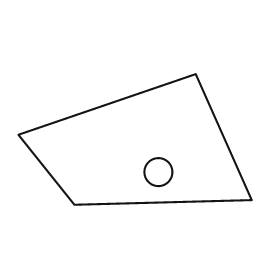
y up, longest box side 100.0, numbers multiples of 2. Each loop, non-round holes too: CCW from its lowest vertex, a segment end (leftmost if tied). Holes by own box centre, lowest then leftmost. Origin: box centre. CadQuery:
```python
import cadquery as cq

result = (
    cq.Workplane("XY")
    .moveTo(-26.0, -28.0)
    .lineTo(50.0, -26.0)
    .lineTo(26.0, 28.0)
    .lineTo(-50.0, 2.0)
    .close()
    .moveTo(10.0, -14.0)
    .circle(6.0)
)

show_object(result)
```